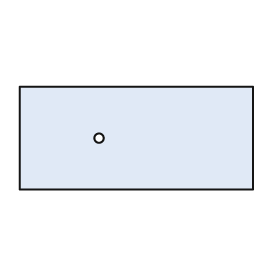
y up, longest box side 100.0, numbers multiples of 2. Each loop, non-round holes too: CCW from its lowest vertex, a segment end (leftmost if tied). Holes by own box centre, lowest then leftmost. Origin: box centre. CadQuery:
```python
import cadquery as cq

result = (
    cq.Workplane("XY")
    .moveTo(-50.0, -22.0)
    .lineTo(50.0, -22.0)
    .lineTo(50.0, 22.0)
    .lineTo(-50.0, 22.0)
    .close()
    .moveTo(-16.0, 0.0)
    .circle(2.0)
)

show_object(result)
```